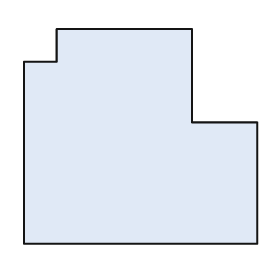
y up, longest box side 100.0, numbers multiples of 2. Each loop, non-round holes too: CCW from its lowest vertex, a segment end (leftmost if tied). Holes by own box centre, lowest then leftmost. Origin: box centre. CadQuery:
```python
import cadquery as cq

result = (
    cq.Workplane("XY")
    .moveTo(-50.0, -46.0)
    .lineTo(50.0, -46.0)
    .lineTo(50.0, 6.0)
    .lineTo(22.0, 6.0)
    .lineTo(22.0, 46.0)
    .lineTo(-36.0, 46.0)
    .lineTo(-36.0, 32.0)
    .lineTo(-50.0, 32.0)
    .close()
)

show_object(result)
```